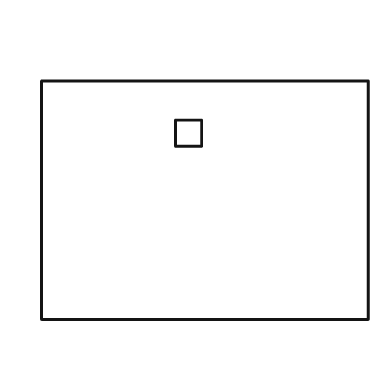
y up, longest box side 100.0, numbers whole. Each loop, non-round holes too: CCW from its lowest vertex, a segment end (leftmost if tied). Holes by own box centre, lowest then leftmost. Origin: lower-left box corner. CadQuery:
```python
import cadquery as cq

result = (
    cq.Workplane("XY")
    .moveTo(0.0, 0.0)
    .lineTo(100.0, 0.0)
    .lineTo(100.0, 73.0)
    .lineTo(0.0, 73.0)
    .close()
    .moveTo(41.0, 53.0)
    .lineTo(49.0, 53.0)
    .lineTo(49.0, 61.0)
    .lineTo(41.0, 61.0)
    .close()
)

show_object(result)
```